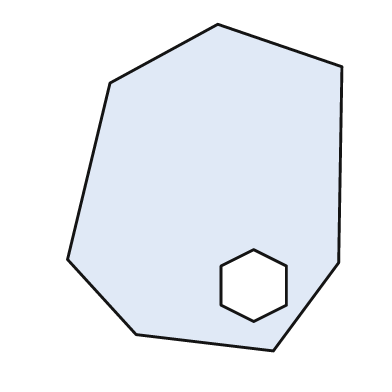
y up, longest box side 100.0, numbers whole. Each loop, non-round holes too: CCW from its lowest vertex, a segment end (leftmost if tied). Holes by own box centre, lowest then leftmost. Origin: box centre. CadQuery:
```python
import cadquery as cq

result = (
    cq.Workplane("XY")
    .moveTo(21.0, -50.0)
    .lineTo(41.0, -23.0)
    .lineTo(42.0, 37.0)
    .lineTo(4.0, 50.0)
    .lineTo(-29.0, 32.0)
    .lineTo(-42.0, -22.0)
    .lineTo(-21.0, -45.0)
    .close()
    .moveTo(15.0, -41.0)
    .lineTo(25.0, -36.0)
    .lineTo(25.0, -24.0)
    .lineTo(15.0, -19.0)
    .lineTo(5.0, -24.0)
    .lineTo(5.0, -36.0)
    .close()
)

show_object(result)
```